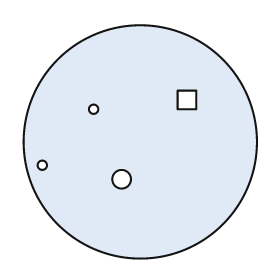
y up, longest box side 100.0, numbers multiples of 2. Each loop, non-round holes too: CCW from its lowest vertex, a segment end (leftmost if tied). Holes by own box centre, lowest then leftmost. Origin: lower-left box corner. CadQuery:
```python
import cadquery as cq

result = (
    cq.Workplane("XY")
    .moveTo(50.0, 50.0)
    .circle(50.0)
    .moveTo(42.0, 34.0)
    .circle(4.0)
    .moveTo(8.0, 40.0)
    .circle(2.0)
    .moveTo(30.0, 64.0)
    .circle(2.0)
    .moveTo(66.0, 64.0)
    .lineTo(74.0, 64.0)
    .lineTo(74.0, 72.0)
    .lineTo(66.0, 72.0)
    .close()
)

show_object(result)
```